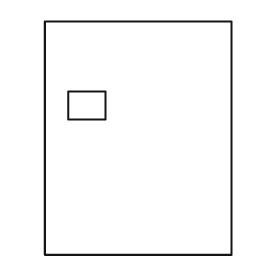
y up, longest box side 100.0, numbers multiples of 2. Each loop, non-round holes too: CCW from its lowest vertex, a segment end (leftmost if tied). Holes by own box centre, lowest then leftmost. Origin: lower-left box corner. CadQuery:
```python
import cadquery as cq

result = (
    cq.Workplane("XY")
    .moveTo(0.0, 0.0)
    .lineTo(80.0, 0.0)
    .lineTo(80.0, 100.0)
    .lineTo(0.0, 100.0)
    .close()
    .moveTo(10.0, 58.0)
    .lineTo(26.0, 58.0)
    .lineTo(26.0, 70.0)
    .lineTo(10.0, 70.0)
    .close()
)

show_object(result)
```